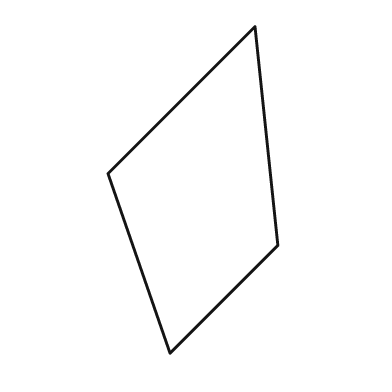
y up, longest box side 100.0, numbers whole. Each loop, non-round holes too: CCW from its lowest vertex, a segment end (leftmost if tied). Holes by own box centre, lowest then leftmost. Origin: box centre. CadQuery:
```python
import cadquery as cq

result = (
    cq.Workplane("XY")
    .moveTo(-7.0, -50.0)
    .lineTo(26.0, -17.0)
    .lineTo(19.0, 50.0)
    .lineTo(-26.0, 5.0)
    .close()
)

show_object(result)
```